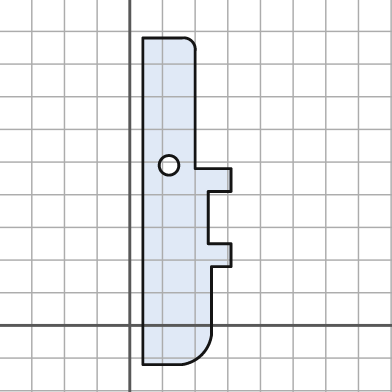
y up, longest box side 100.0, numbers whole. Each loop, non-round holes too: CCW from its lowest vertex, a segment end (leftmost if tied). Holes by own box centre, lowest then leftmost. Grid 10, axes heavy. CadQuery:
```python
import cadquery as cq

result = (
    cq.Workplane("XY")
    .moveTo(4.0, -12.0)
    .lineTo(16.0, -12.0)
    .threePointArc((22.0, -9.0), (25.0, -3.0))
    .lineTo(25.0, 18.0)
    .lineTo(31.0, 18.0)
    .lineTo(31.0, 25.0)
    .lineTo(24.0, 25.0)
    .lineTo(24.0, 41.0)
    .lineTo(31.0, 41.0)
    .lineTo(31.0, 48.0)
    .lineTo(20.0, 48.0)
    .lineTo(20.0, 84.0)
    .threePointArc((19.0, 87.0), (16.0, 88.0))
    .lineTo(4.0, 88.0)
    .close()
    .moveTo(12.0, 49.0)
    .circle(3.0)
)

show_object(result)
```